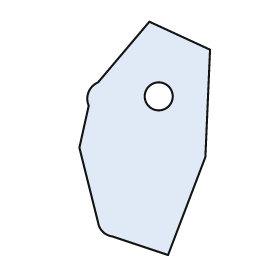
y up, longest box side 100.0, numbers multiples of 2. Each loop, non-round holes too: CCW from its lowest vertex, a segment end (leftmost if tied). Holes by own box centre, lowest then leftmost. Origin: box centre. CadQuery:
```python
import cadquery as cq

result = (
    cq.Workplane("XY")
    .moveTo(10.0, -50.0)
    .lineTo(26.0, -8.0)
    .lineTo(28.0, 38.0)
    .lineTo(2.0, 50.0)
    .lineTo(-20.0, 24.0)
    .threePointArc((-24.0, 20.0), (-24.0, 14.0))
    .lineTo(-28.0, -4.0)
    .lineTo(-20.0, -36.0)
    .threePointArc((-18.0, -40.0), (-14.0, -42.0))
    .close()
    .moveTo(6.0, 18.0)
    .circle(6.0)
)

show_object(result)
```